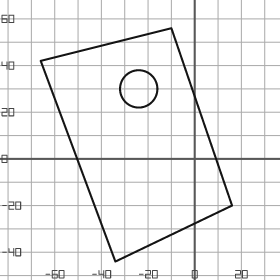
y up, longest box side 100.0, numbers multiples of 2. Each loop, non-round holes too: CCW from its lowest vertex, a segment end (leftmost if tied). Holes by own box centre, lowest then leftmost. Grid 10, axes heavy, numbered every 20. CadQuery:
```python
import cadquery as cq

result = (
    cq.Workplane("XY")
    .moveTo(-34.0, -44.0)
    .lineTo(16.0, -20.0)
    .lineTo(-10.0, 56.0)
    .lineTo(-66.0, 42.0)
    .close()
    .moveTo(-24.0, 30.0)
    .circle(8.0)
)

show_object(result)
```